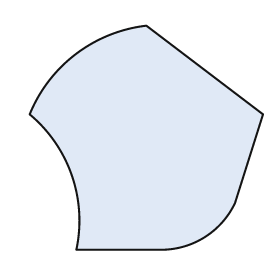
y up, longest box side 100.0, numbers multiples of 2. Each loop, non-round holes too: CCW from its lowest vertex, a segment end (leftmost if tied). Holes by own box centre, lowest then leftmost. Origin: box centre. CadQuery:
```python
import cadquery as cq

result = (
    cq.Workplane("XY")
    .moveTo(-30.0, -48.0)
    .lineTo(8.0, -48.0)
    .threePointArc((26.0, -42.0), (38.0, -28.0))
    .lineTo(50.0, 10.0)
    .lineTo(0.0, 48.0)
    .threePointArc((-30.0, 36.0), (-50.0, 10.0))
    .threePointArc((-32.0, -16.0), (-30.0, -48.0))
    .close()
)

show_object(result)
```